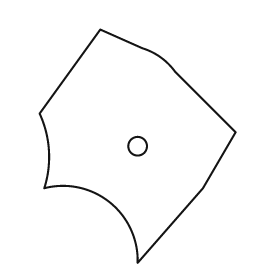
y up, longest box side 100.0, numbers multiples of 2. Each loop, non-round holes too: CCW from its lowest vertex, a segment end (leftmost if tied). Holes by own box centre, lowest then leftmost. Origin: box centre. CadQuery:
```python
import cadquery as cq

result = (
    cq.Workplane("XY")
    .moveTo(0.0, -50.0)
    .lineTo(28.0, -18.0)
    .lineTo(42.0, 6.0)
    .lineTo(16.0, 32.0)
    .threePointArc((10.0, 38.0), (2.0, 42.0))
    .lineTo(-16.0, 50.0)
    .lineTo(-42.0, 14.0)
    .threePointArc((-38.0, -2.0), (-40.0, -18.0))
    .threePointArc((-12.0, -24.0), (0.0, -50.0))
    .close()
    .moveTo(0.0, 0.0)
    .circle(4.0)
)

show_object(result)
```